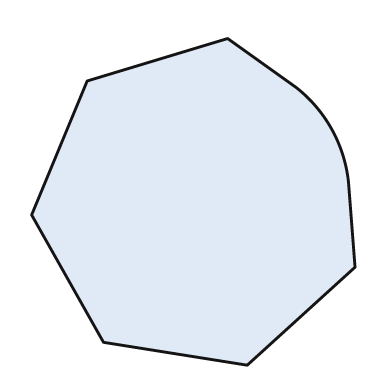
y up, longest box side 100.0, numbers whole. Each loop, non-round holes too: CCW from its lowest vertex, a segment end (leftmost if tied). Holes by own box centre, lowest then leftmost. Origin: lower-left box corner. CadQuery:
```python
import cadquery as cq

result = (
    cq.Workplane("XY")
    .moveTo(66.0, 0.0)
    .lineTo(99.0, 30.0)
    .lineTo(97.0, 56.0)
    .threePointArc((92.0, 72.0), (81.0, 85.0))
    .lineTo(60.0, 100.0)
    .lineTo(17.0, 87.0)
    .lineTo(0.0, 46.0)
    .lineTo(22.0, 7.0)
    .close()
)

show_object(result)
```